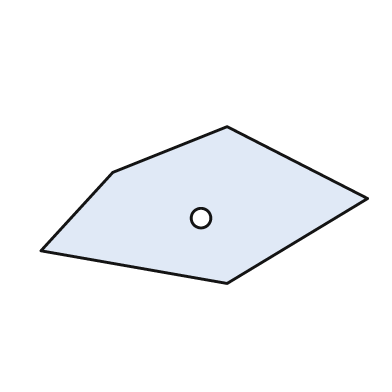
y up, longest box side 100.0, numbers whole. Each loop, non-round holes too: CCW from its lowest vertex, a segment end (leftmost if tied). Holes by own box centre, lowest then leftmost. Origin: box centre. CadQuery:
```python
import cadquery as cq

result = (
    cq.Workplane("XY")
    .moveTo(7.0, -24.0)
    .lineTo(50.0, 2.0)
    .lineTo(7.0, 24.0)
    .lineTo(-28.0, 10.0)
    .lineTo(-50.0, -14.0)
    .close()
    .moveTo(-1.0, -4.0)
    .circle(3.0)
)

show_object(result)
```